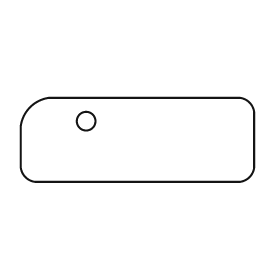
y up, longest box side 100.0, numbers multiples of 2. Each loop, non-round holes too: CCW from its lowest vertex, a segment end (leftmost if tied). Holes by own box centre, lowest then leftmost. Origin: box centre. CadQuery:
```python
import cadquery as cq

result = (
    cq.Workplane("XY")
    .moveTo(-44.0, -18.0)
    .lineTo(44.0, -18.0)
    .threePointArc((48.0, -16.0), (50.0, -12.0))
    .lineTo(50.0, 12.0)
    .threePointArc((48.0, 16.0), (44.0, 18.0))
    .lineTo(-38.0, 18.0)
    .threePointArc((-46.0, 14.0), (-50.0, 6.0))
    .lineTo(-50.0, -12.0)
    .threePointArc((-48.0, -16.0), (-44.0, -18.0))
    .close()
    .moveTo(-22.0, 8.0)
    .circle(4.0)
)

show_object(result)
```